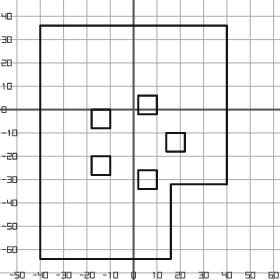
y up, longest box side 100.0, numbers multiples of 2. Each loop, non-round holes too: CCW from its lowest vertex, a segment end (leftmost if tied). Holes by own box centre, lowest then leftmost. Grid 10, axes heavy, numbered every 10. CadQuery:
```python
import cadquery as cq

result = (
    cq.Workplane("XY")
    .moveTo(-40.0, -64.0)
    .lineTo(16.0, -64.0)
    .lineTo(16.0, -32.0)
    .lineTo(40.0, -32.0)
    .lineTo(40.0, 36.0)
    .lineTo(-40.0, 36.0)
    .close()
    .moveTo(2.0, -34.0)
    .lineTo(10.0, -34.0)
    .lineTo(10.0, -26.0)
    .lineTo(2.0, -26.0)
    .close()
    .moveTo(-18.0, -28.0)
    .lineTo(-10.0, -28.0)
    .lineTo(-10.0, -20.0)
    .lineTo(-18.0, -20.0)
    .close()
    .moveTo(14.0, -18.0)
    .lineTo(22.0, -18.0)
    .lineTo(22.0, -10.0)
    .lineTo(14.0, -10.0)
    .close()
    .moveTo(-18.0, -8.0)
    .lineTo(-10.0, -8.0)
    .lineTo(-10.0, 0.0)
    .lineTo(-18.0, 0.0)
    .close()
    .moveTo(2.0, -2.0)
    .lineTo(10.0, -2.0)
    .lineTo(10.0, 6.0)
    .lineTo(2.0, 6.0)
    .close()
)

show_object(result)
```